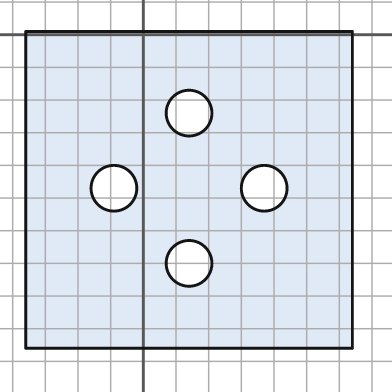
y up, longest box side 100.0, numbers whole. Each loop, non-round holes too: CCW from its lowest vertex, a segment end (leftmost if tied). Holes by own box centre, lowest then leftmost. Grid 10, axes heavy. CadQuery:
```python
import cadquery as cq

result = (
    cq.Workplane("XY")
    .moveTo(-36.0, -96.0)
    .lineTo(64.0, -96.0)
    .lineTo(64.0, 1.0)
    .lineTo(-36.0, 1.0)
    .close()
    .moveTo(14.0, -70.0)
    .circle(7.0)
    .moveTo(-9.0, -47.0)
    .circle(7.0)
    .moveTo(37.0, -47.0)
    .circle(7.0)
    .moveTo(14.0, -24.0)
    .circle(7.0)
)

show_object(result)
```